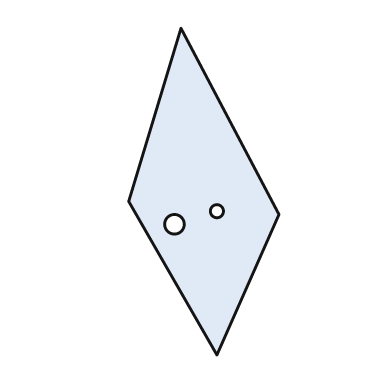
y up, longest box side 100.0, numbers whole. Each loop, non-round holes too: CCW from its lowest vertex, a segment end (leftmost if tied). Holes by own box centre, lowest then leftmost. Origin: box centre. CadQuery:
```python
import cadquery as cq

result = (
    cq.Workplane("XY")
    .moveTo(4.0, -50.0)
    .lineTo(23.0, -7.0)
    .lineTo(-7.0, 50.0)
    .lineTo(-23.0, -3.0)
    .close()
    .moveTo(-9.0, -10.0)
    .circle(3.0)
    .moveTo(4.0, -6.0)
    .circle(2.0)
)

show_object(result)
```